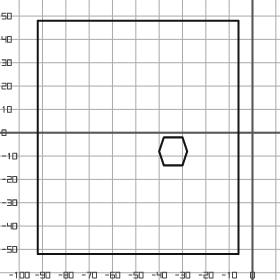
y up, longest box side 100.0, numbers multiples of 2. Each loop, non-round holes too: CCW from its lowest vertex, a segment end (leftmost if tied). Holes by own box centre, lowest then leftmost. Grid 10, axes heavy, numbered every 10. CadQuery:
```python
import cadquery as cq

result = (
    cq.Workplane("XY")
    .moveTo(-92.0, -52.0)
    .lineTo(-6.0, -52.0)
    .lineTo(-6.0, 48.0)
    .lineTo(-92.0, 48.0)
    .close()
    .moveTo(-38.0, -14.0)
    .lineTo(-30.0, -14.0)
    .lineTo(-28.0, -8.0)
    .lineTo(-30.0, -2.0)
    .lineTo(-38.0, -2.0)
    .lineTo(-40.0, -8.0)
    .close()
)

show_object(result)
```